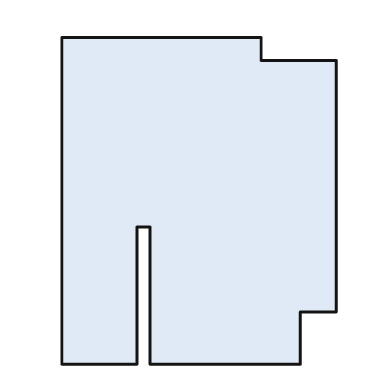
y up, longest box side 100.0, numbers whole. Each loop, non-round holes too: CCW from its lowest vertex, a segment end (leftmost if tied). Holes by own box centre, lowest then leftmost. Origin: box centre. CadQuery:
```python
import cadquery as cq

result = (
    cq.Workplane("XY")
    .moveTo(-42.0, -50.0)
    .lineTo(-19.0, -50.0)
    .lineTo(-19.0, -8.0)
    .lineTo(-15.0, -8.0)
    .lineTo(-15.0, -50.0)
    .lineTo(31.0, -50.0)
    .lineTo(31.0, -34.0)
    .lineTo(42.0, -34.0)
    .lineTo(42.0, 43.0)
    .lineTo(19.0, 43.0)
    .lineTo(19.0, 50.0)
    .lineTo(-42.0, 50.0)
    .close()
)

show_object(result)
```